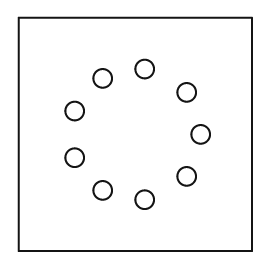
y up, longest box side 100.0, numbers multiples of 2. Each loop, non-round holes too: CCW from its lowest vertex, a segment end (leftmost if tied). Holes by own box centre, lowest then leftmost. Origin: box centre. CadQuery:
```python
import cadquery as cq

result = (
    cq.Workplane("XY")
    .moveTo(-50.0, -50.0)
    .lineTo(50.0, -50.0)
    .lineTo(50.0, 50.0)
    .lineTo(-50.0, 50.0)
    .close()
    .moveTo(4.0, -28.0)
    .circle(4.0)
    .moveTo(-14.0, -24.0)
    .circle(4.0)
    .moveTo(22.0, -18.0)
    .circle(4.0)
    .moveTo(-26.0, -10.0)
    .circle(4.0)
    .moveTo(28.0, 0.0)
    .circle(4.0)
    .moveTo(-26.0, 10.0)
    .circle(4.0)
    .moveTo(22.0, 18.0)
    .circle(4.0)
    .moveTo(-14.0, 24.0)
    .circle(4.0)
    .moveTo(4.0, 28.0)
    .circle(4.0)
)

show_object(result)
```